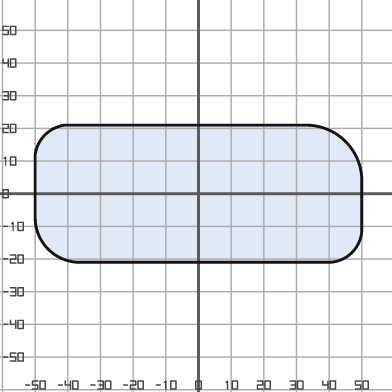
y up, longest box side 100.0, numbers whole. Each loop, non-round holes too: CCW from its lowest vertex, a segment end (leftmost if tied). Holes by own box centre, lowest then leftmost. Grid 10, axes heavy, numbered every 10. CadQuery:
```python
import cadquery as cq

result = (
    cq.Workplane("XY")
    .moveTo(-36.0, -21.0)
    .lineTo(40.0, -21.0)
    .threePointArc((47.0, -18.0), (50.0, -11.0))
    .lineTo(50.0, 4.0)
    .threePointArc((45.0, 16.0), (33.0, 21.0))
    .lineTo(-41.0, 21.0)
    .threePointArc((-47.0, 18.0), (-50.0, 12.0))
    .lineTo(-50.0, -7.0)
    .threePointArc((-46.0, -17.0), (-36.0, -21.0))
    .close()
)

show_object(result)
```